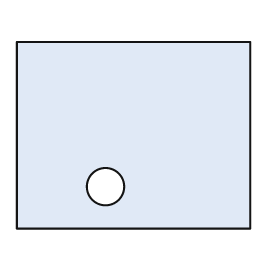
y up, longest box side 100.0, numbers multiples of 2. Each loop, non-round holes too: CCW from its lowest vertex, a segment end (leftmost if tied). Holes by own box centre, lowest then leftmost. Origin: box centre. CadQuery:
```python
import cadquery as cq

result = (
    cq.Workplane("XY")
    .moveTo(-50.0, -40.0)
    .lineTo(50.0, -40.0)
    .lineTo(50.0, 40.0)
    .lineTo(-50.0, 40.0)
    .close()
    .moveTo(-12.0, -22.0)
    .circle(8.0)
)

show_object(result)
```